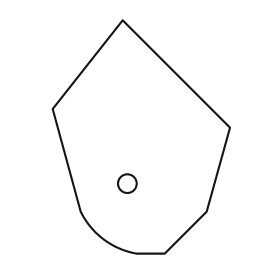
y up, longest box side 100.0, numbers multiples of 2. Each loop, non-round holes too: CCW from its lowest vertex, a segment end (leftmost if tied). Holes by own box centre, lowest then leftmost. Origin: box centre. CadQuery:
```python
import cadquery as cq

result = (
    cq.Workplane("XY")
    .moveTo(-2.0, -50.0)
    .lineTo(10.0, -50.0)
    .lineTo(28.0, -32.0)
    .lineTo(38.0, 4.0)
    .lineTo(-8.0, 50.0)
    .lineTo(-38.0, 12.0)
    .lineTo(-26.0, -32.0)
    .threePointArc((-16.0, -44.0), (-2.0, -50.0))
    .close()
    .moveTo(-6.0, -20.0)
    .circle(4.0)
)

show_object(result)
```